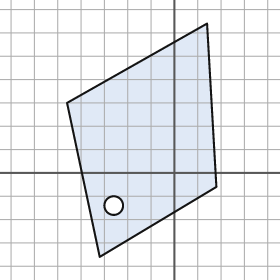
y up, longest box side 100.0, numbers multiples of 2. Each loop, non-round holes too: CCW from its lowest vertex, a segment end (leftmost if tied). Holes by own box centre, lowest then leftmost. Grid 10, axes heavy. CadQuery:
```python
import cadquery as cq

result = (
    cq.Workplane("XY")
    .moveTo(-32.0, -36.0)
    .lineTo(18.0, -6.0)
    .lineTo(14.0, 64.0)
    .lineTo(-46.0, 30.0)
    .close()
    .moveTo(-26.0, -14.0)
    .circle(4.0)
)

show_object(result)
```